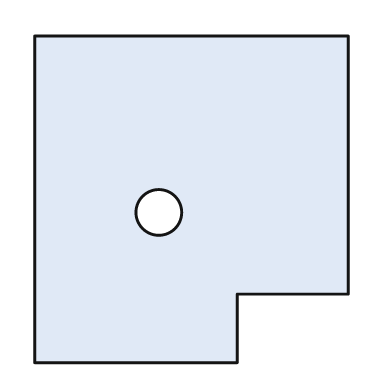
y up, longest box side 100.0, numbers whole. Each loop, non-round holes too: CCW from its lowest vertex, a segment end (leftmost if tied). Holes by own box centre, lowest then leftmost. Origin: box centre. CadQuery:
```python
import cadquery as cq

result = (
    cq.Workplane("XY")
    .moveTo(-48.0, -50.0)
    .lineTo(14.0, -50.0)
    .lineTo(14.0, -29.0)
    .lineTo(48.0, -29.0)
    .lineTo(48.0, 50.0)
    .lineTo(-48.0, 50.0)
    .close()
    .moveTo(-10.0, -4.0)
    .circle(7.0)
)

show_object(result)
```